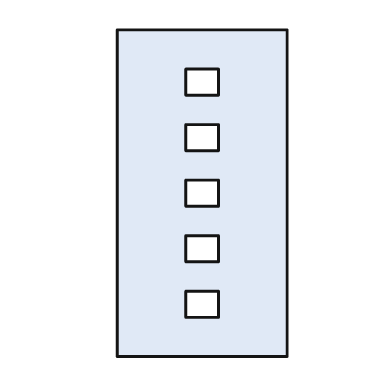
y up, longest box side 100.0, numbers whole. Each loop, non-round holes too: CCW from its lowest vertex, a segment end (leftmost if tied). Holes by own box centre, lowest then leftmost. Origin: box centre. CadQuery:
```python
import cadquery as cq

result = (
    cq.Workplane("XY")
    .moveTo(-26.0, -50.0)
    .lineTo(26.0, -50.0)
    .lineTo(26.0, 50.0)
    .lineTo(-26.0, 50.0)
    .close()
    .moveTo(-5.0, -38.0)
    .lineTo(5.0, -38.0)
    .lineTo(5.0, -30.0)
    .lineTo(-5.0, -30.0)
    .close()
    .moveTo(-5.0, -21.0)
    .lineTo(5.0, -21.0)
    .lineTo(5.0, -13.0)
    .lineTo(-5.0, -13.0)
    .close()
    .moveTo(-5.0, -4.0)
    .lineTo(5.0, -4.0)
    .lineTo(5.0, 4.0)
    .lineTo(-5.0, 4.0)
    .close()
    .moveTo(-5.0, 13.0)
    .lineTo(5.0, 13.0)
    .lineTo(5.0, 21.0)
    .lineTo(-5.0, 21.0)
    .close()
    .moveTo(-5.0, 30.0)
    .lineTo(5.0, 30.0)
    .lineTo(5.0, 38.0)
    .lineTo(-5.0, 38.0)
    .close()
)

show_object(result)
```